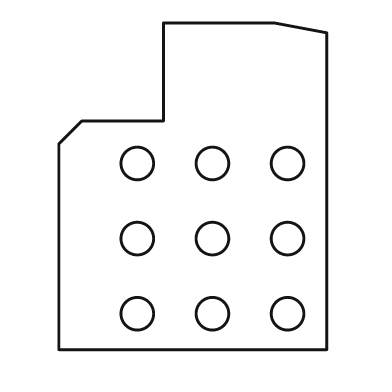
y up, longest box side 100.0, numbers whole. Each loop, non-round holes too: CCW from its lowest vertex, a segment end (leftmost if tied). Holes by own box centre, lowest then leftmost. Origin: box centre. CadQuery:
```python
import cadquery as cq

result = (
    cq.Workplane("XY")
    .moveTo(-41.0, -50.0)
    .lineTo(41.0, -50.0)
    .lineTo(41.0, 47.0)
    .lineTo(25.0, 50.0)
    .lineTo(-9.0, 50.0)
    .lineTo(-9.0, 20.0)
    .lineTo(-34.0, 20.0)
    .lineTo(-41.0, 13.0)
    .close()
    .moveTo(-17.0, -39.0)
    .circle(5.0)
    .moveTo(6.0, -39.0)
    .circle(5.0)
    .moveTo(29.0, -39.0)
    .circle(5.0)
    .moveTo(-17.0, -16.0)
    .circle(5.0)
    .moveTo(6.0, -16.0)
    .circle(5.0)
    .moveTo(29.0, -16.0)
    .circle(5.0)
    .moveTo(-17.0, 7.0)
    .circle(5.0)
    .moveTo(6.0, 7.0)
    .circle(5.0)
    .moveTo(29.0, 7.0)
    .circle(5.0)
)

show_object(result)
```